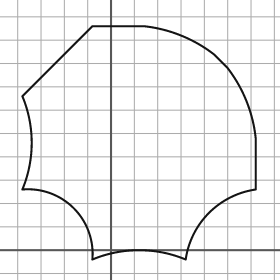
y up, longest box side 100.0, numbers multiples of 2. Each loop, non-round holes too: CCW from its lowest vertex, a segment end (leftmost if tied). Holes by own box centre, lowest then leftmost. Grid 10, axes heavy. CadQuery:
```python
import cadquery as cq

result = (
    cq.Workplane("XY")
    .moveTo(-8.0, -4.0)
    .threePointArc((12.0, 0.0), (32.0, -4.0))
    .threePointArc((42.0, 16.0), (62.0, 26.0))
    .lineTo(62.0, 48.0)
    .threePointArc((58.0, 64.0), (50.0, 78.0))
    .lineTo(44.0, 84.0)
    .threePointArc((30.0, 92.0), (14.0, 96.0))
    .lineTo(-8.0, 96.0)
    .lineTo(-38.0, 66.0)
    .threePointArc((-34.0, 46.0), (-38.0, 26.0))
    .threePointArc((-16.0, 18.0), (-8.0, -4.0))
    .close()
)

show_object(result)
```